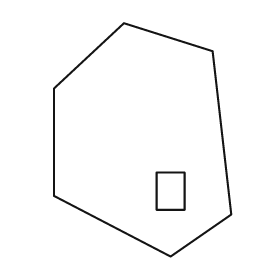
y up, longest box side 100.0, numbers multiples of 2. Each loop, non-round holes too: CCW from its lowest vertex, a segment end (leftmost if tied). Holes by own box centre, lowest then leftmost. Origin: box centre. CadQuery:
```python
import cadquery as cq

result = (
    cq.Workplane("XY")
    .moveTo(12.0, -50.0)
    .lineTo(38.0, -32.0)
    .lineTo(30.0, 38.0)
    .lineTo(-8.0, 50.0)
    .lineTo(-38.0, 22.0)
    .lineTo(-38.0, -24.0)
    .close()
    .moveTo(6.0, -30.0)
    .lineTo(18.0, -30.0)
    .lineTo(18.0, -14.0)
    .lineTo(6.0, -14.0)
    .close()
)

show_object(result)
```